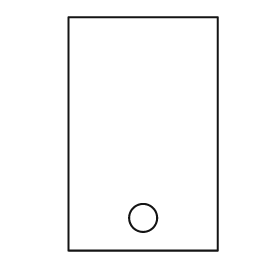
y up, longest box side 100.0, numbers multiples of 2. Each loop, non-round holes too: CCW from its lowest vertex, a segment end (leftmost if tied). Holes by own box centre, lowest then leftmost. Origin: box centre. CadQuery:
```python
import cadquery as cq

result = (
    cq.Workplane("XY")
    .moveTo(-32.0, -50.0)
    .lineTo(32.0, -50.0)
    .lineTo(32.0, 50.0)
    .lineTo(-32.0, 50.0)
    .close()
    .moveTo(0.0, -36.0)
    .circle(6.0)
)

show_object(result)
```